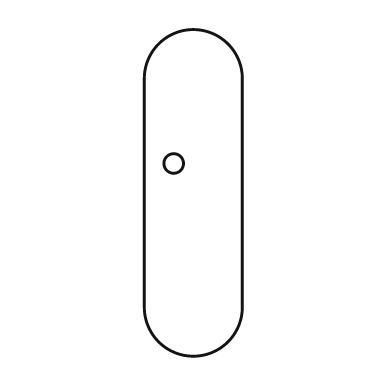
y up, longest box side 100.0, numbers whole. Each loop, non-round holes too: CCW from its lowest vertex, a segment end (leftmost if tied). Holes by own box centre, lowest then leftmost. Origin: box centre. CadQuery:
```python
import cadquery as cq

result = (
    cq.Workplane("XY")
    .moveTo(-15.0, -35.0)
    .threePointArc((0.0, -50.0), (15.0, -35.0))
    .lineTo(15.0, 35.0)
    .threePointArc((0.0, 50.0), (-15.0, 35.0))
    .close()
    .moveTo(-6.0, 9.0)
    .circle(3.0)
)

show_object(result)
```